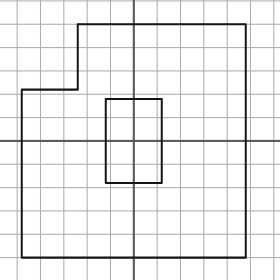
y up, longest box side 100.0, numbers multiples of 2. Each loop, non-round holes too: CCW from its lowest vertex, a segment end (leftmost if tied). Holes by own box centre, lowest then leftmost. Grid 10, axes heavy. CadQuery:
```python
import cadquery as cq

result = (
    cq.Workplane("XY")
    .moveTo(-48.0, -50.0)
    .lineTo(48.0, -50.0)
    .lineTo(48.0, 50.0)
    .lineTo(-24.0, 50.0)
    .lineTo(-24.0, 22.0)
    .lineTo(-48.0, 22.0)
    .close()
    .moveTo(-12.0, -18.0)
    .lineTo(12.0, -18.0)
    .lineTo(12.0, 18.0)
    .lineTo(-12.0, 18.0)
    .close()
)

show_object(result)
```